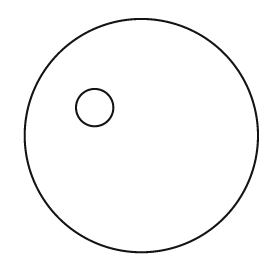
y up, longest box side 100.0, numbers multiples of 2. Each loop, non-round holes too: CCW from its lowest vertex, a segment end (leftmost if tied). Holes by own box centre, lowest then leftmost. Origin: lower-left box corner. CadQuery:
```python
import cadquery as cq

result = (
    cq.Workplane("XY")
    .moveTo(50.0, 50.0)
    .circle(50.0)
    .moveTo(30.0, 62.0)
    .circle(8.0)
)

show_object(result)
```